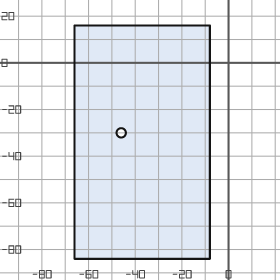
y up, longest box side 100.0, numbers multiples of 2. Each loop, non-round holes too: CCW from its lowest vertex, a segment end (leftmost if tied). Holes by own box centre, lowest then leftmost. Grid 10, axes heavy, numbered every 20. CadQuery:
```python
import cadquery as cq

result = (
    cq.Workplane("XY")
    .moveTo(-66.0, -84.0)
    .lineTo(-8.0, -84.0)
    .lineTo(-8.0, 16.0)
    .lineTo(-66.0, 16.0)
    .close()
    .moveTo(-46.0, -30.0)
    .circle(2.0)
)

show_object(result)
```